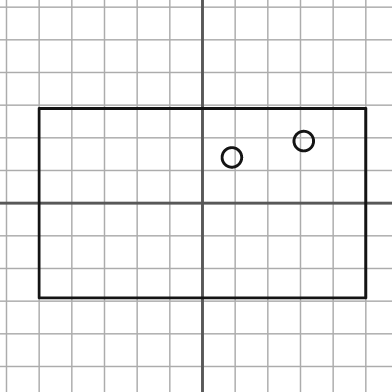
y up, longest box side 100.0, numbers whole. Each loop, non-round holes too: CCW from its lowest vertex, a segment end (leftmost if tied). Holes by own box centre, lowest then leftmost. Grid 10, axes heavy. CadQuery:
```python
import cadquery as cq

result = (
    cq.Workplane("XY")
    .moveTo(-50.0, -29.0)
    .lineTo(50.0, -29.0)
    .lineTo(50.0, 29.0)
    .lineTo(-50.0, 29.0)
    .close()
    .moveTo(9.0, 14.0)
    .circle(3.0)
    .moveTo(31.0, 19.0)
    .circle(3.0)
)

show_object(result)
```